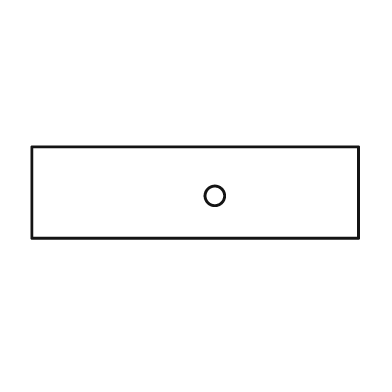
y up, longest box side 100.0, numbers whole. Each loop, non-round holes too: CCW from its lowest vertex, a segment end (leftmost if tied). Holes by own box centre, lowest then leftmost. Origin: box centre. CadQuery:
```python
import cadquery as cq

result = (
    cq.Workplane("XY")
    .moveTo(-50.0, -14.0)
    .lineTo(50.0, -14.0)
    .lineTo(50.0, 14.0)
    .lineTo(-50.0, 14.0)
    .close()
    .moveTo(6.0, -1.0)
    .circle(3.0)
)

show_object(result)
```